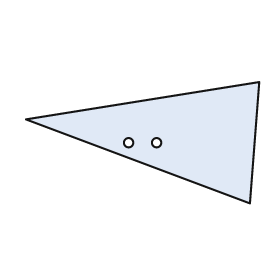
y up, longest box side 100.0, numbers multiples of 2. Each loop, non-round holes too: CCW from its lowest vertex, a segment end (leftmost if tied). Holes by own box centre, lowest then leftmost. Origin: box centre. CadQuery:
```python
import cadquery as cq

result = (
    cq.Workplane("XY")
    .moveTo(46.0, -26.0)
    .lineTo(50.0, 26.0)
    .lineTo(-50.0, 10.0)
    .close()
    .moveTo(-6.0, 0.0)
    .circle(2.0)
    .moveTo(6.0, 0.0)
    .circle(2.0)
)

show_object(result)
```